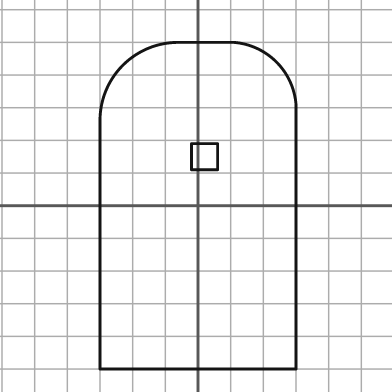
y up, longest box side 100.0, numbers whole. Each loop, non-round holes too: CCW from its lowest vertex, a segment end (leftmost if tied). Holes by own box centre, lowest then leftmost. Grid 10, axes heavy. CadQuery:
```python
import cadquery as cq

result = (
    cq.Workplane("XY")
    .moveTo(-30.0, -50.0)
    .lineTo(30.0, -50.0)
    .lineTo(30.0, 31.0)
    .threePointArc((24.0, 44.0), (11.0, 50.0))
    .lineTo(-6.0, 50.0)
    .threePointArc((-23.0, 43.0), (-30.0, 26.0))
    .close()
    .moveTo(-2.0, 11.0)
    .lineTo(6.0, 11.0)
    .lineTo(6.0, 19.0)
    .lineTo(-2.0, 19.0)
    .close()
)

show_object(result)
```